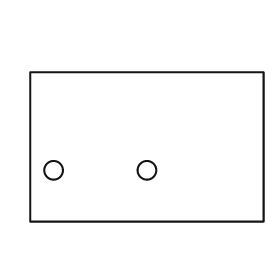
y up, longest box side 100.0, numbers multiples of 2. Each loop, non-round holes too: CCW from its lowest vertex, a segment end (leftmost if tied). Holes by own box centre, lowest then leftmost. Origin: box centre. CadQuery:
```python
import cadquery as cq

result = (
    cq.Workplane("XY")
    .moveTo(-50.0, -32.0)
    .lineTo(50.0, -32.0)
    .lineTo(50.0, 32.0)
    .lineTo(-50.0, 32.0)
    .close()
    .moveTo(-40.0, -10.0)
    .circle(4.0)
    .moveTo(0.0, -10.0)
    .circle(4.0)
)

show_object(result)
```